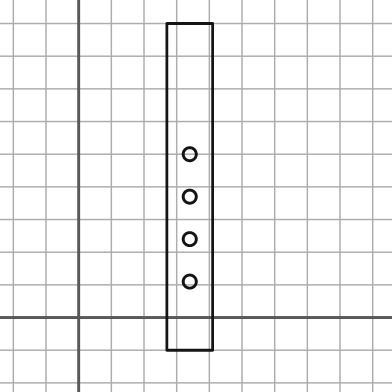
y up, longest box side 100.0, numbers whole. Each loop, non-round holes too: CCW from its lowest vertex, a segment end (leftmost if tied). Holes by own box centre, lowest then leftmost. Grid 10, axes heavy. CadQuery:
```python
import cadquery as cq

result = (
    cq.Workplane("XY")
    .moveTo(27.0, -10.0)
    .lineTo(41.0, -10.0)
    .lineTo(41.0, 90.0)
    .lineTo(27.0, 90.0)
    .close()
    .moveTo(34.0, 11.0)
    .circle(2.0)
    .moveTo(34.0, 24.0)
    .circle(2.0)
    .moveTo(34.0, 37.0)
    .circle(2.0)
    .moveTo(34.0, 50.0)
    .circle(2.0)
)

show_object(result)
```